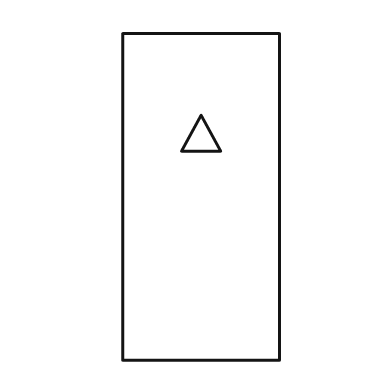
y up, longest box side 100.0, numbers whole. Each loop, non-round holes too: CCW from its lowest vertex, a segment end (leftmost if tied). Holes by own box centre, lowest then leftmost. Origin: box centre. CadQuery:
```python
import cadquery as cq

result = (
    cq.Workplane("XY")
    .moveTo(-24.0, -50.0)
    .lineTo(24.0, -50.0)
    .lineTo(24.0, 50.0)
    .lineTo(-24.0, 50.0)
    .close()
    .moveTo(-6.0, 14.0)
    .lineTo(6.0, 14.0)
    .lineTo(0.0, 25.0)
    .close()
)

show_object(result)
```